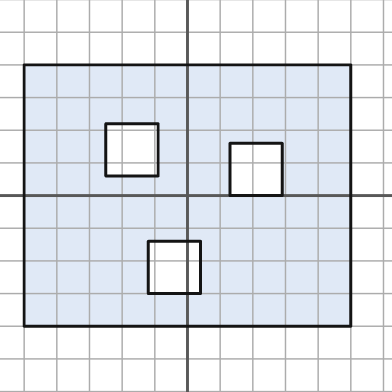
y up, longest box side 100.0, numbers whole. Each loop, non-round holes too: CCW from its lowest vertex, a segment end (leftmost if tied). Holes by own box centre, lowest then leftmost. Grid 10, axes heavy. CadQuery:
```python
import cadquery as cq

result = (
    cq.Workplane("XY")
    .moveTo(-50.0, -40.0)
    .lineTo(50.0, -40.0)
    .lineTo(50.0, 40.0)
    .lineTo(-50.0, 40.0)
    .close()
    .moveTo(-12.0, -30.0)
    .lineTo(4.0, -30.0)
    .lineTo(4.0, -14.0)
    .lineTo(-12.0, -14.0)
    .close()
    .moveTo(13.0, 0.0)
    .lineTo(29.0, 0.0)
    .lineTo(29.0, 16.0)
    .lineTo(13.0, 16.0)
    .close()
    .moveTo(-25.0, 6.0)
    .lineTo(-9.0, 6.0)
    .lineTo(-9.0, 22.0)
    .lineTo(-25.0, 22.0)
    .close()
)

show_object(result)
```